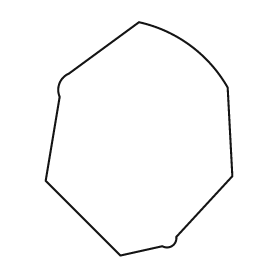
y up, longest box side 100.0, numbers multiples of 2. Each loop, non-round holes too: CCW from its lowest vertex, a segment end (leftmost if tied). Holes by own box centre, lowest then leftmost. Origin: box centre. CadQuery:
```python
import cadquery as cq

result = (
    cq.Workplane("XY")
    .moveTo(-8.0, -50.0)
    .lineTo(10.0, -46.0)
    .threePointArc((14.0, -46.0), (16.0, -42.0))
    .lineTo(40.0, -16.0)
    .lineTo(38.0, 22.0)
    .threePointArc((22.0, 40.0), (0.0, 50.0))
    .lineTo(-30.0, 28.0)
    .threePointArc((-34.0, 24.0), (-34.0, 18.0))
    .lineTo(-40.0, -18.0)
    .close()
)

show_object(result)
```